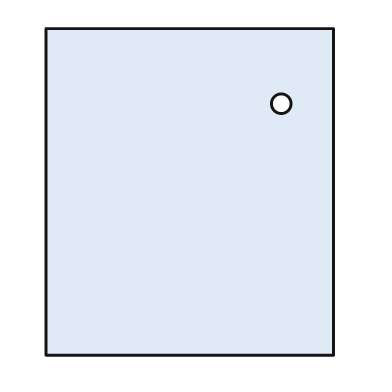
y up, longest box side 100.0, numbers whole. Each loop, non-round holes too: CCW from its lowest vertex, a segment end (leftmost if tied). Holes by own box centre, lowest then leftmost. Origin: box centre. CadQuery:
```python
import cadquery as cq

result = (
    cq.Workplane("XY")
    .moveTo(-44.0, -50.0)
    .lineTo(44.0, -50.0)
    .lineTo(44.0, 50.0)
    .lineTo(-44.0, 50.0)
    .close()
    .moveTo(28.0, 27.0)
    .circle(3.0)
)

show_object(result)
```